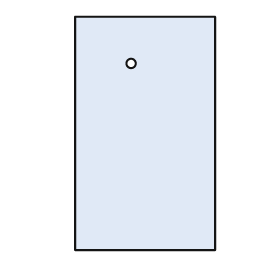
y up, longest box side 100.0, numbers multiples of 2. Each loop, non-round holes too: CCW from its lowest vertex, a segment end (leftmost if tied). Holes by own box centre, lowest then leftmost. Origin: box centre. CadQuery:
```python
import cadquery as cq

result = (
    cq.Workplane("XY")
    .moveTo(-30.0, -50.0)
    .lineTo(30.0, -50.0)
    .lineTo(30.0, 50.0)
    .lineTo(-30.0, 50.0)
    .close()
    .moveTo(-6.0, 30.0)
    .circle(2.0)
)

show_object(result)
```